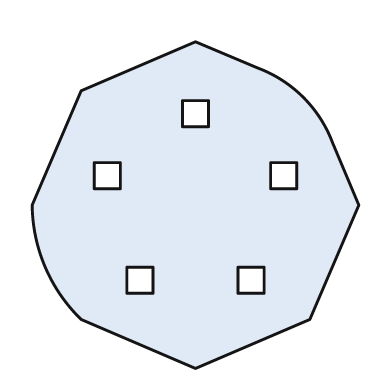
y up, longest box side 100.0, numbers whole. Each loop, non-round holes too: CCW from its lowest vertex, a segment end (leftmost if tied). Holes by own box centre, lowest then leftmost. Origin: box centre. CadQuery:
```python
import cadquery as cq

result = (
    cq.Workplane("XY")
    .moveTo(0.0, -50.0)
    .lineTo(35.0, -35.0)
    .lineTo(50.0, 0.0)
    .lineTo(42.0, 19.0)
    .threePointArc((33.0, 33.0), (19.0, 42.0))
    .lineTo(0.0, 50.0)
    .lineTo(-35.0, 35.0)
    .lineTo(-50.0, 0.0)
    .threePointArc((-46.0, -19.0), (-35.0, -35.0))
    .close()
    .moveTo(-21.0, -27.0)
    .lineTo(-13.0, -27.0)
    .lineTo(-13.0, -19.0)
    .lineTo(-21.0, -19.0)
    .close()
    .moveTo(13.0, -27.0)
    .lineTo(21.0, -27.0)
    .lineTo(21.0, -19.0)
    .lineTo(13.0, -19.0)
    .close()
    .moveTo(-31.0, 5.0)
    .lineTo(-23.0, 5.0)
    .lineTo(-23.0, 13.0)
    .lineTo(-31.0, 13.0)
    .close()
    .moveTo(23.0, 5.0)
    .lineTo(31.0, 5.0)
    .lineTo(31.0, 13.0)
    .lineTo(23.0, 13.0)
    .close()
    .moveTo(-4.0, 24.0)
    .lineTo(4.0, 24.0)
    .lineTo(4.0, 32.0)
    .lineTo(-4.0, 32.0)
    .close()
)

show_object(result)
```